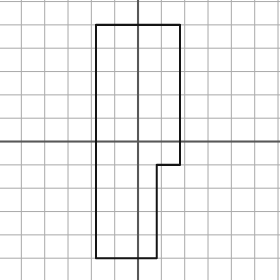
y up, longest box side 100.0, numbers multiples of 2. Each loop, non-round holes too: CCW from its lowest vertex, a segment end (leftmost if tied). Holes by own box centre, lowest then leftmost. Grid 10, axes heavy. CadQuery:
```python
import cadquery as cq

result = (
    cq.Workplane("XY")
    .moveTo(-18.0, -50.0)
    .lineTo(8.0, -50.0)
    .lineTo(8.0, -10.0)
    .lineTo(18.0, -10.0)
    .lineTo(18.0, 50.0)
    .lineTo(-18.0, 50.0)
    .close()
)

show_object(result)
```